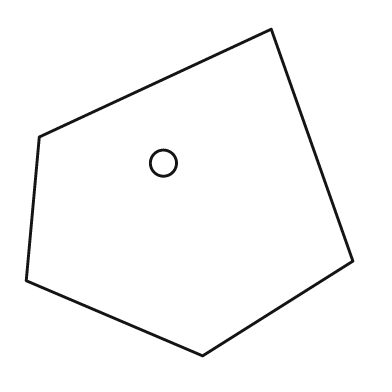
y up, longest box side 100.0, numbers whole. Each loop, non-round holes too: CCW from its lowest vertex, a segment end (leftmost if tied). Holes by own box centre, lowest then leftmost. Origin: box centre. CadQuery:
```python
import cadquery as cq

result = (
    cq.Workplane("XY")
    .moveTo(4.0, -50.0)
    .lineTo(50.0, -21.0)
    .lineTo(25.0, 50.0)
    .lineTo(-46.0, 17.0)
    .lineTo(-50.0, -27.0)
    .close()
    .moveTo(-8.0, 9.0)
    .circle(4.0)
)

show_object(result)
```